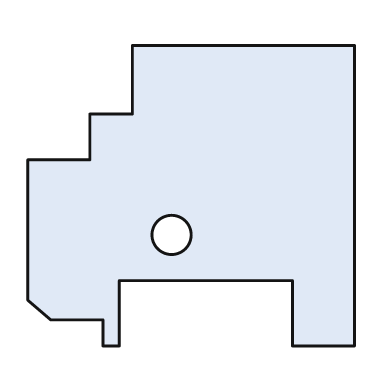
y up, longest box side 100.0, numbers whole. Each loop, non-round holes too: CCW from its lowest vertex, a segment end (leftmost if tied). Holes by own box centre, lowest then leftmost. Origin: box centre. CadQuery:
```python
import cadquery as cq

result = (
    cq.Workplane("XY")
    .moveTo(-27.0, -46.0)
    .lineTo(-22.0, -46.0)
    .lineTo(-22.0, -26.0)
    .lineTo(31.0, -26.0)
    .lineTo(31.0, -46.0)
    .lineTo(50.0, -46.0)
    .lineTo(50.0, 46.0)
    .lineTo(-18.0, 46.0)
    .lineTo(-18.0, 25.0)
    .lineTo(-31.0, 25.0)
    .lineTo(-31.0, 11.0)
    .lineTo(-50.0, 11.0)
    .lineTo(-50.0, -32.0)
    .lineTo(-43.0, -38.0)
    .lineTo(-27.0, -38.0)
    .close()
    .moveTo(-6.0, -12.0)
    .circle(6.0)
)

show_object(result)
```